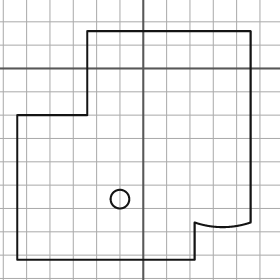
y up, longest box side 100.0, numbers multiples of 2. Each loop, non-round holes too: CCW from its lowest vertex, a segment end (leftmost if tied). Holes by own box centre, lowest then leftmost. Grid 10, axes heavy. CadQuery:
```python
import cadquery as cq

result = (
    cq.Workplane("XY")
    .moveTo(-54.0, -82.0)
    .lineTo(22.0, -82.0)
    .lineTo(22.0, -66.0)
    .threePointArc((34.0, -68.0), (46.0, -66.0))
    .lineTo(46.0, 16.0)
    .lineTo(-24.0, 16.0)
    .lineTo(-24.0, -20.0)
    .lineTo(-54.0, -20.0)
    .close()
    .moveTo(-10.0, -56.0)
    .circle(4.0)
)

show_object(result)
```